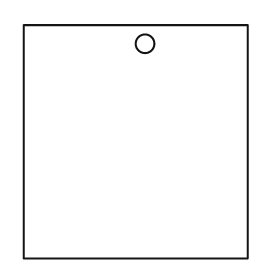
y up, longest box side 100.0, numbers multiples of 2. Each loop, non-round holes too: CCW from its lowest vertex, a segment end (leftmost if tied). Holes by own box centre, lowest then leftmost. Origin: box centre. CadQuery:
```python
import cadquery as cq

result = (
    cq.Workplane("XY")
    .moveTo(-48.0, -50.0)
    .lineTo(48.0, -50.0)
    .lineTo(48.0, 50.0)
    .lineTo(-48.0, 50.0)
    .close()
    .moveTo(4.0, 42.0)
    .circle(4.0)
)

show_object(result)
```